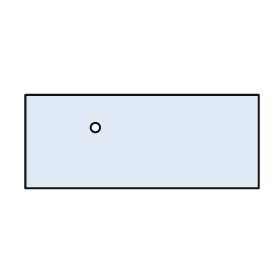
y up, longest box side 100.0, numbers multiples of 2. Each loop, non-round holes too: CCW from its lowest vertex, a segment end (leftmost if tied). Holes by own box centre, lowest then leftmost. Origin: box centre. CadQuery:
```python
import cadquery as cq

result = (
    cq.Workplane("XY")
    .moveTo(-50.0, -20.0)
    .lineTo(50.0, -20.0)
    .lineTo(50.0, 20.0)
    .lineTo(-50.0, 20.0)
    .close()
    .moveTo(-20.0, 6.0)
    .circle(2.0)
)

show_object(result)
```